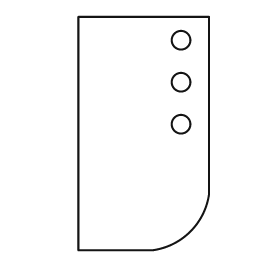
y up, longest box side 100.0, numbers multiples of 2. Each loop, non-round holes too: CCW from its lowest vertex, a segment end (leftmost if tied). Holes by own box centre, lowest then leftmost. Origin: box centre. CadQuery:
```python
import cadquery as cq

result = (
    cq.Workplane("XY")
    .moveTo(-28.0, -50.0)
    .lineTo(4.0, -50.0)
    .threePointArc((20.0, -42.0), (28.0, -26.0))
    .lineTo(28.0, 50.0)
    .lineTo(-28.0, 50.0)
    .close()
    .moveTo(16.0, 4.0)
    .circle(4.0)
    .moveTo(16.0, 22.0)
    .circle(4.0)
    .moveTo(16.0, 40.0)
    .circle(4.0)
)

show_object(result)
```